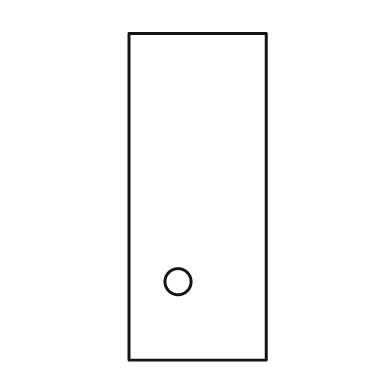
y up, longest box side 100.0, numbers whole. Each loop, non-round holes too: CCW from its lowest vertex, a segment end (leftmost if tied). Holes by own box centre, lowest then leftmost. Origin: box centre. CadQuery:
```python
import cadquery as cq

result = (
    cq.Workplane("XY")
    .moveTo(-21.0, -50.0)
    .lineTo(21.0, -50.0)
    .lineTo(21.0, 50.0)
    .lineTo(-21.0, 50.0)
    .close()
    .moveTo(-6.0, -26.0)
    .circle(4.0)
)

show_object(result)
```